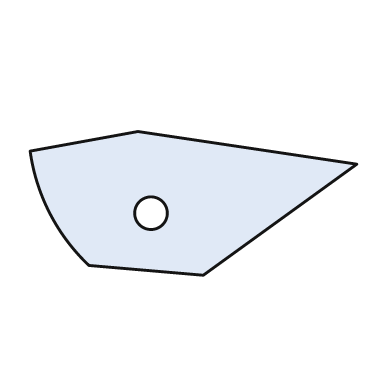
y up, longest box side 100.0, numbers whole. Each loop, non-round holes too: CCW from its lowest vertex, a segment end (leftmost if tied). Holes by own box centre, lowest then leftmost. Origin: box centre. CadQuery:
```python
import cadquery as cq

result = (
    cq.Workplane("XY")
    .moveTo(3.0, -22.0)
    .lineTo(50.0, 12.0)
    .lineTo(-17.0, 22.0)
    .lineTo(-50.0, 16.0)
    .threePointArc((-44.0, -3.0), (-32.0, -19.0))
    .close()
    .moveTo(-13.0, -3.0)
    .circle(5.0)
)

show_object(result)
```